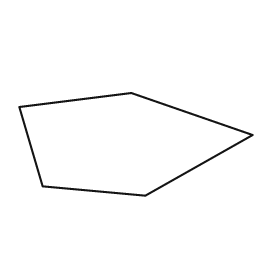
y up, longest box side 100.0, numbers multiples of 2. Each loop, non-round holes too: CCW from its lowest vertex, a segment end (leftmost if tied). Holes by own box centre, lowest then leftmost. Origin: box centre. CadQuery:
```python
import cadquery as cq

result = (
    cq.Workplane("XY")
    .moveTo(4.0, -22.0)
    .lineTo(50.0, 4.0)
    .lineTo(-2.0, 22.0)
    .lineTo(-50.0, 16.0)
    .lineTo(-40.0, -18.0)
    .close()
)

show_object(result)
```